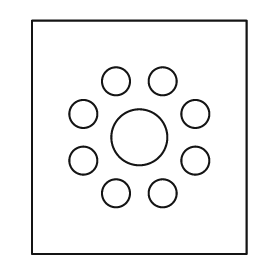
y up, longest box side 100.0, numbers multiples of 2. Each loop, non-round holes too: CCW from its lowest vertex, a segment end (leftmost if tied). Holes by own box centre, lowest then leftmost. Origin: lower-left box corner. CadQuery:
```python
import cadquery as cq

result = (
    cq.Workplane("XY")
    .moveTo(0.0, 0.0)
    .lineTo(92.0, 0.0)
    .lineTo(92.0, 100.0)
    .lineTo(0.0, 100.0)
    .close()
    .moveTo(36.0, 26.0)
    .circle(6.0)
    .moveTo(56.0, 26.0)
    .circle(6.0)
    .moveTo(22.0, 40.0)
    .circle(6.0)
    .moveTo(70.0, 40.0)
    .circle(6.0)
    .moveTo(46.0, 50.0)
    .circle(12.0)
    .moveTo(22.0, 60.0)
    .circle(6.0)
    .moveTo(70.0, 60.0)
    .circle(6.0)
    .moveTo(36.0, 74.0)
    .circle(6.0)
    .moveTo(56.0, 74.0)
    .circle(6.0)
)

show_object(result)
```